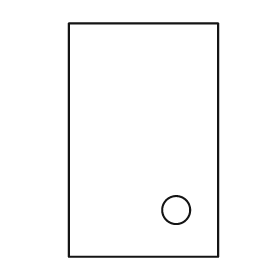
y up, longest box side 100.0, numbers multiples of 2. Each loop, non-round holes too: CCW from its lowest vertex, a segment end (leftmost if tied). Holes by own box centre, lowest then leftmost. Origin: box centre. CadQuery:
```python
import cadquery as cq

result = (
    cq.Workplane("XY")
    .moveTo(-32.0, -50.0)
    .lineTo(32.0, -50.0)
    .lineTo(32.0, 50.0)
    .lineTo(-32.0, 50.0)
    .close()
    .moveTo(14.0, -30.0)
    .circle(6.0)
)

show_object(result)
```